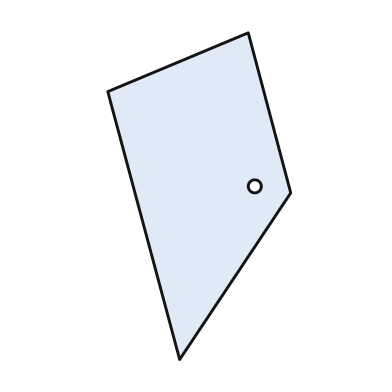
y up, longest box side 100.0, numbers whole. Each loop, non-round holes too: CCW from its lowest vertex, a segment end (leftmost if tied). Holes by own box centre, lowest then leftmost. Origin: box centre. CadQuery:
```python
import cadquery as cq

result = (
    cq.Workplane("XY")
    .moveTo(-6.0, -50.0)
    .lineTo(28.0, 1.0)
    .lineTo(15.0, 50.0)
    .lineTo(-28.0, 32.0)
    .close()
    .moveTo(17.0, 3.0)
    .circle(2.0)
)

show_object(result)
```